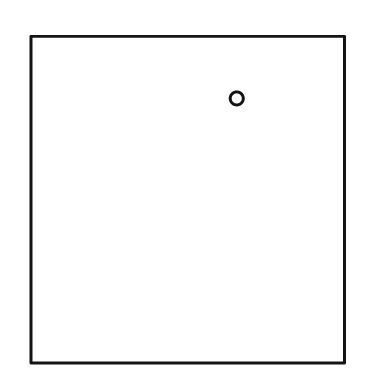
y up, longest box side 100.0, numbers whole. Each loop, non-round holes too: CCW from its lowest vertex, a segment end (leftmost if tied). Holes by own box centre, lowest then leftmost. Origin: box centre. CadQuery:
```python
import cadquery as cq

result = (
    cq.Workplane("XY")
    .moveTo(-48.0, -50.0)
    .lineTo(48.0, -50.0)
    .lineTo(48.0, 50.0)
    .lineTo(-48.0, 50.0)
    .close()
    .moveTo(15.0, 31.0)
    .circle(2.0)
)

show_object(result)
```